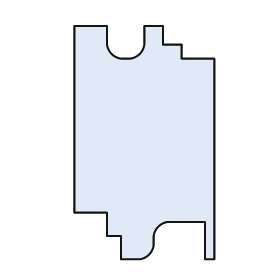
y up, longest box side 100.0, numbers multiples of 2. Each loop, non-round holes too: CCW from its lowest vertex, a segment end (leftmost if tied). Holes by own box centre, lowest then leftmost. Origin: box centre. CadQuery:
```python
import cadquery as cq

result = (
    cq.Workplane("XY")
    .moveTo(-10.0, -50.0)
    .lineTo(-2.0, -50.0)
    .threePointArc((2.0, -48.0), (4.0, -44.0))
    .lineTo(4.0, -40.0)
    .threePointArc((6.0, -36.0), (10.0, -34.0))
    .lineTo(26.0, -34.0)
    .lineTo(26.0, -50.0)
    .lineTo(30.0, -50.0)
    .lineTo(30.0, 36.0)
    .lineTo(16.0, 36.0)
    .lineTo(16.0, 42.0)
    .lineTo(8.0, 42.0)
    .lineTo(8.0, 50.0)
    .lineTo(0.0, 50.0)
    .lineTo(0.0, 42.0)
    .threePointArc((-2.0, 38.0), (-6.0, 36.0))
    .lineTo(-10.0, 36.0)
    .threePointArc((-14.0, 38.0), (-16.0, 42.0))
    .lineTo(-16.0, 50.0)
    .lineTo(-30.0, 50.0)
    .lineTo(-30.0, -30.0)
    .lineTo(-16.0, -30.0)
    .lineTo(-16.0, -40.0)
    .lineTo(-10.0, -40.0)
    .close()
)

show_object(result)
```